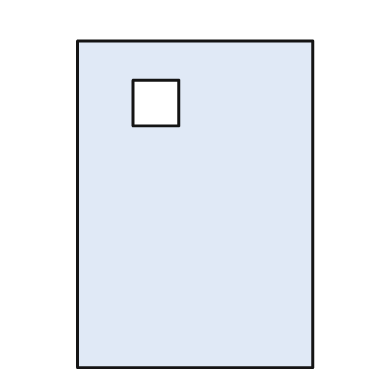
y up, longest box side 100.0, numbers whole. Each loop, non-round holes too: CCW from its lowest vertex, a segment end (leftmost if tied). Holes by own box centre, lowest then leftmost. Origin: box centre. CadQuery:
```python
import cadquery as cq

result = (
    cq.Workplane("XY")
    .moveTo(-36.0, -50.0)
    .lineTo(36.0, -50.0)
    .lineTo(36.0, 50.0)
    .lineTo(-36.0, 50.0)
    .close()
    .moveTo(-19.0, 24.0)
    .lineTo(-5.0, 24.0)
    .lineTo(-5.0, 38.0)
    .lineTo(-19.0, 38.0)
    .close()
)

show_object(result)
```